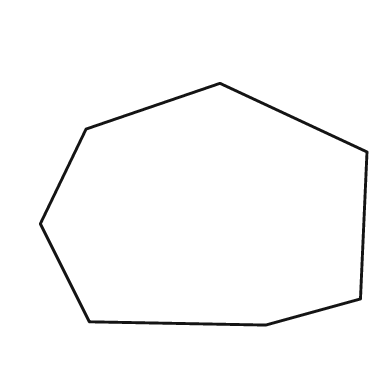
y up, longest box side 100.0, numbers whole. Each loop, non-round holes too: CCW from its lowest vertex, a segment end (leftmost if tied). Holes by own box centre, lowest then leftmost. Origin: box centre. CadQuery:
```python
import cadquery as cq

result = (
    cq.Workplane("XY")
    .moveTo(19.0, -37.0)
    .lineTo(48.0, -29.0)
    .lineTo(50.0, 16.0)
    .lineTo(5.0, 37.0)
    .lineTo(-36.0, 23.0)
    .lineTo(-50.0, -6.0)
    .lineTo(-35.0, -36.0)
    .close()
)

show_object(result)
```